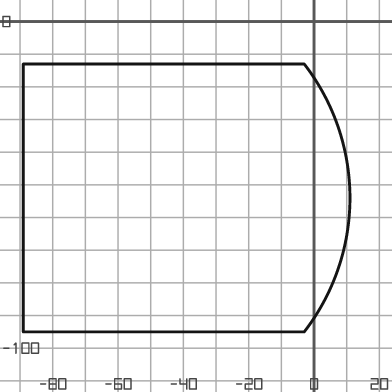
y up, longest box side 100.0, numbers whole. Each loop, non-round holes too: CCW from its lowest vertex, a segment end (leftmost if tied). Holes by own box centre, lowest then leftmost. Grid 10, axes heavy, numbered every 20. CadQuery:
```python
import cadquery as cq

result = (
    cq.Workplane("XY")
    .moveTo(-89.0, -95.0)
    .lineTo(-3.0, -95.0)
    .threePointArc((11.0, -54.0), (-3.0, -13.0))
    .lineTo(-89.0, -13.0)
    .close()
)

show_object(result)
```